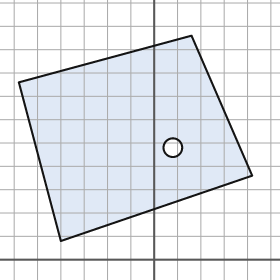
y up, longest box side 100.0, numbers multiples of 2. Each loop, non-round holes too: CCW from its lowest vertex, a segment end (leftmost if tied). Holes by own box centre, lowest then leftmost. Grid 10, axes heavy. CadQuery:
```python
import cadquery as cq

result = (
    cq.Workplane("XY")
    .moveTo(-40.0, 8.0)
    .lineTo(42.0, 36.0)
    .lineTo(16.0, 96.0)
    .lineTo(-58.0, 76.0)
    .close()
    .moveTo(8.0, 48.0)
    .circle(4.0)
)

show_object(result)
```